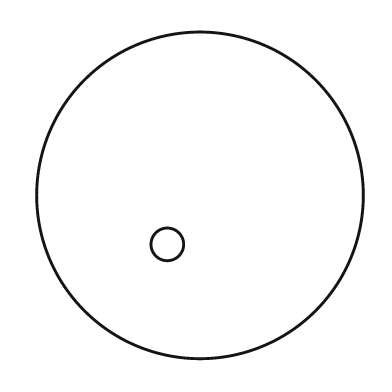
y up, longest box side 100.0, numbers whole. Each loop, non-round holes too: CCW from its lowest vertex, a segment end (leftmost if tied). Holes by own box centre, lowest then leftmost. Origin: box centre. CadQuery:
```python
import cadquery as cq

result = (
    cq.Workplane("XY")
    .moveTo(0.0, 0.0)
    .circle(50.0)
    .moveTo(-10.0, -15.0)
    .circle(5.0)
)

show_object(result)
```